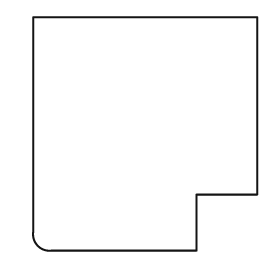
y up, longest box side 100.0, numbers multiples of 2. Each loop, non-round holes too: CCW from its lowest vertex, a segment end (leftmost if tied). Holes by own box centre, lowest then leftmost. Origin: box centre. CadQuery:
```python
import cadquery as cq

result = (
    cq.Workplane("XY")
    .moveTo(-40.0, -50.0)
    .lineTo(22.0, -50.0)
    .lineTo(22.0, -26.0)
    .lineTo(48.0, -26.0)
    .lineTo(48.0, 50.0)
    .lineTo(-48.0, 50.0)
    .lineTo(-48.0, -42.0)
    .threePointArc((-46.0, -48.0), (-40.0, -50.0))
    .close()
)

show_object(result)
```